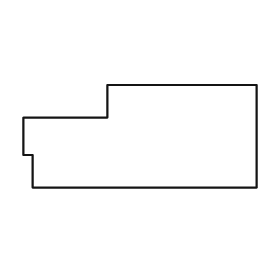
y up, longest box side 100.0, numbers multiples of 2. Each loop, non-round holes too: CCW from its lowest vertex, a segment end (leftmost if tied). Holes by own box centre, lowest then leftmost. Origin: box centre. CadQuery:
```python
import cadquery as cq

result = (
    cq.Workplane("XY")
    .moveTo(-46.0, -22.0)
    .lineTo(50.0, -22.0)
    .lineTo(50.0, 22.0)
    .lineTo(-14.0, 22.0)
    .lineTo(-14.0, 8.0)
    .lineTo(-50.0, 8.0)
    .lineTo(-50.0, -8.0)
    .lineTo(-46.0, -8.0)
    .close()
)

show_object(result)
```